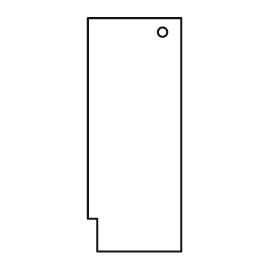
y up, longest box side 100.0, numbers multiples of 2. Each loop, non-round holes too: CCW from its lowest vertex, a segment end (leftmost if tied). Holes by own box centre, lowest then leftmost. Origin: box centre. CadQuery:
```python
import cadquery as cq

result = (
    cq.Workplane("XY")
    .moveTo(-16.0, -50.0)
    .lineTo(20.0, -50.0)
    .lineTo(20.0, 50.0)
    .lineTo(-20.0, 50.0)
    .lineTo(-20.0, -36.0)
    .lineTo(-16.0, -36.0)
    .close()
    .moveTo(12.0, 44.0)
    .circle(2.0)
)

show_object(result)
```